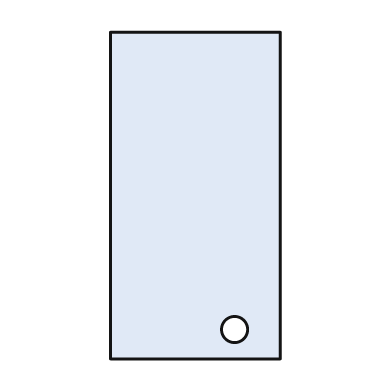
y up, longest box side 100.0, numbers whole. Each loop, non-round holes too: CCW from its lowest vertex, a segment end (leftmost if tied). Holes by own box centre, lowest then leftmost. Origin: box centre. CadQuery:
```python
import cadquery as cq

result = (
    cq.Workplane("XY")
    .moveTo(-26.0, -50.0)
    .lineTo(26.0, -50.0)
    .lineTo(26.0, 50.0)
    .lineTo(-26.0, 50.0)
    .close()
    .moveTo(12.0, -41.0)
    .circle(4.0)
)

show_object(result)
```